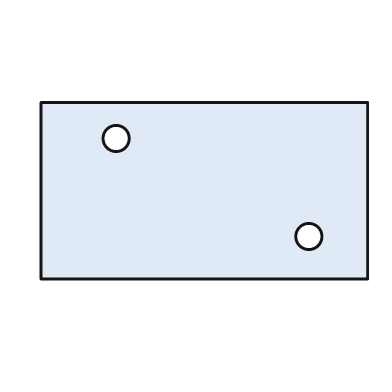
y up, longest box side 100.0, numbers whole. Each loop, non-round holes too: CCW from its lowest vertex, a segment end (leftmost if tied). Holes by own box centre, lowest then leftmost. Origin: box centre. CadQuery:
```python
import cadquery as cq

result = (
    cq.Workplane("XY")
    .moveTo(-50.0, -27.0)
    .lineTo(50.0, -27.0)
    .lineTo(50.0, 27.0)
    .lineTo(-50.0, 27.0)
    .close()
    .moveTo(32.0, -14.0)
    .circle(4.0)
    .moveTo(-27.0, 16.0)
    .circle(4.0)
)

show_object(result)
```